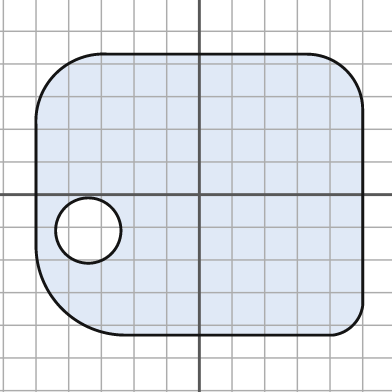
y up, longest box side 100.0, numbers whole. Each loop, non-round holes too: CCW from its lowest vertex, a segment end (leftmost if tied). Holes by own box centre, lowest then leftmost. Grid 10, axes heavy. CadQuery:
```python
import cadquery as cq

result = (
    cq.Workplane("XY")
    .moveTo(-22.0, -43.0)
    .lineTo(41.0, -43.0)
    .threePointArc((47.0, -40.0), (50.0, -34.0))
    .lineTo(50.0, 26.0)
    .threePointArc((45.0, 38.0), (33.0, 43.0))
    .lineTo(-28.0, 43.0)
    .threePointArc((-44.0, 37.0), (-50.0, 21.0))
    .lineTo(-50.0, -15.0)
    .threePointArc((-42.0, -35.0), (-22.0, -43.0))
    .close()
    .moveTo(-34.0, -11.0)
    .circle(10.0)
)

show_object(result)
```